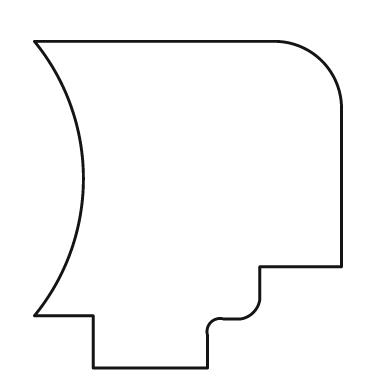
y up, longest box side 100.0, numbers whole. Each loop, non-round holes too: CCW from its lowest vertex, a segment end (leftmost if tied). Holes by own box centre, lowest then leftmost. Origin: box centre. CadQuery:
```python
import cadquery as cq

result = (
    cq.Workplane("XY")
    .moveTo(-29.0, -50.0)
    .lineTo(6.0, -50.0)
    .lineTo(6.0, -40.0)
    .threePointArc((7.0, -36.0), (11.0, -35.0))
    .lineTo(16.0, -35.0)
    .threePointArc((20.0, -33.0), (22.0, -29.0))
    .lineTo(22.0, -19.0)
    .lineTo(47.0, -19.0)
    .lineTo(47.0, 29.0)
    .threePointArc((41.0, 44.0), (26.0, 50.0))
    .lineTo(-47.0, 50.0)
    .threePointArc((-32.0, 8.0), (-47.0, -34.0))
    .lineTo(-29.0, -34.0)
    .close()
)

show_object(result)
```